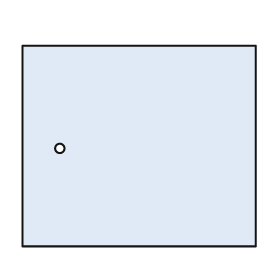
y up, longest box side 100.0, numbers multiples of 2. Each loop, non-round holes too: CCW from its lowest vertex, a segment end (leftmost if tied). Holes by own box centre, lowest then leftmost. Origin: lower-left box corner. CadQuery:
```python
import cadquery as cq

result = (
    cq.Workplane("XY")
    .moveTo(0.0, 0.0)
    .lineTo(100.0, 0.0)
    .lineTo(100.0, 86.0)
    .lineTo(0.0, 86.0)
    .close()
    .moveTo(16.0, 42.0)
    .circle(2.0)
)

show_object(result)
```